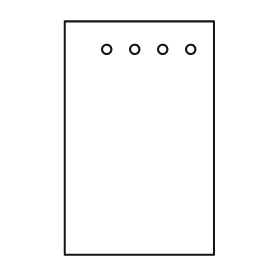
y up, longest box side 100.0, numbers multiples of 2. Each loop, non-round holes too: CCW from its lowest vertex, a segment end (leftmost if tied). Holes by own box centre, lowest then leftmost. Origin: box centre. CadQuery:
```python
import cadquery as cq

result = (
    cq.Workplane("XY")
    .moveTo(-32.0, -50.0)
    .lineTo(32.0, -50.0)
    .lineTo(32.0, 50.0)
    .lineTo(-32.0, 50.0)
    .close()
    .moveTo(-14.0, 38.0)
    .circle(2.0)
    .moveTo(-2.0, 38.0)
    .circle(2.0)
    .moveTo(10.0, 38.0)
    .circle(2.0)
    .moveTo(22.0, 38.0)
    .circle(2.0)
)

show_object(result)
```